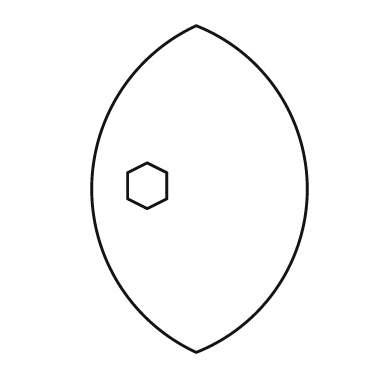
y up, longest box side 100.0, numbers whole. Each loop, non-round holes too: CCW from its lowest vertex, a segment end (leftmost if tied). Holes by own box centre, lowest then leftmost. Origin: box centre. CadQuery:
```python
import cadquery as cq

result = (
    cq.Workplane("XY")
    .moveTo(-1.0, -50.0)
    .threePointArc((33.0, 0.0), (-1.0, 50.0))
    .threePointArc((-33.0, 0.0), (-1.0, -50.0))
    .close()
    .moveTo(-16.0, -6.0)
    .lineTo(-10.0, -3.0)
    .lineTo(-10.0, 5.0)
    .lineTo(-16.0, 8.0)
    .lineTo(-22.0, 5.0)
    .lineTo(-22.0, -3.0)
    .close()
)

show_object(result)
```